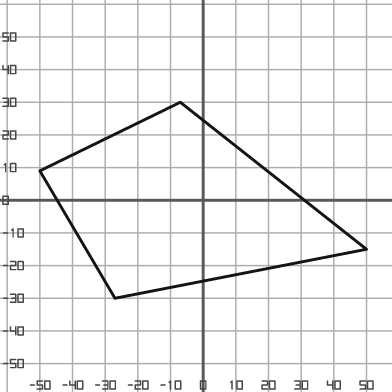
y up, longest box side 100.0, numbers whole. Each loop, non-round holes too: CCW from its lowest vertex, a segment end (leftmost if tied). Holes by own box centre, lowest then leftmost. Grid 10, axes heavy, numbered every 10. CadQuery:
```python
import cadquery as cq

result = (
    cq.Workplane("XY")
    .moveTo(-27.0, -30.0)
    .lineTo(50.0, -15.0)
    .lineTo(-7.0, 30.0)
    .lineTo(-50.0, 9.0)
    .close()
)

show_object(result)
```